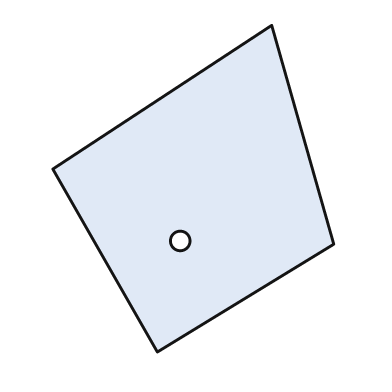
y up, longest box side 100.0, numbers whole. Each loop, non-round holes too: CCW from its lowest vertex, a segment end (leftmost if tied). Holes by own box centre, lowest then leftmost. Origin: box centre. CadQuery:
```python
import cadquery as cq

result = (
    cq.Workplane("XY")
    .moveTo(-11.0, -50.0)
    .lineTo(43.0, -17.0)
    .lineTo(24.0, 50.0)
    .lineTo(-43.0, 6.0)
    .close()
    .moveTo(-4.0, -16.0)
    .circle(3.0)
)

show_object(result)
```